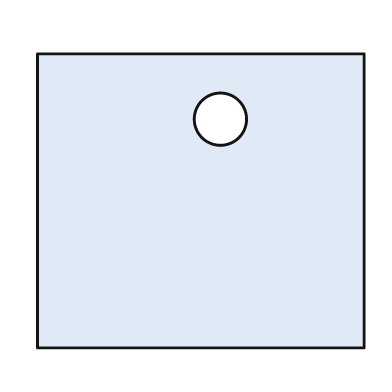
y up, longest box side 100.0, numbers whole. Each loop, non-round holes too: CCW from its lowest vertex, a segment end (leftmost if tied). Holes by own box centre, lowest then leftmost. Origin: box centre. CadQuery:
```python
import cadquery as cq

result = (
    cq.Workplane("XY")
    .moveTo(-50.0, -45.0)
    .lineTo(50.0, -45.0)
    .lineTo(50.0, 45.0)
    .lineTo(-50.0, 45.0)
    .close()
    .moveTo(6.0, 25.0)
    .circle(8.0)
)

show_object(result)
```